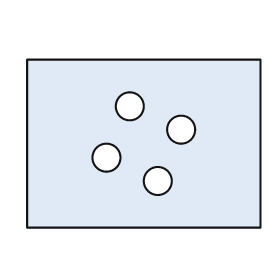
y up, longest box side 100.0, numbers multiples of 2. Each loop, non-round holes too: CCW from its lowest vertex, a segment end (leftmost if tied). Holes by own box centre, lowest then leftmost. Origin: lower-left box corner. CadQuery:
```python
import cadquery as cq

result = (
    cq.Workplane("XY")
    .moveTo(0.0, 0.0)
    .lineTo(100.0, 0.0)
    .lineTo(100.0, 72.0)
    .lineTo(0.0, 72.0)
    .close()
    .moveTo(56.0, 20.0)
    .circle(6.0)
    .moveTo(34.0, 30.0)
    .circle(6.0)
    .moveTo(66.0, 42.0)
    .circle(6.0)
    .moveTo(44.0, 52.0)
    .circle(6.0)
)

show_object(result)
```